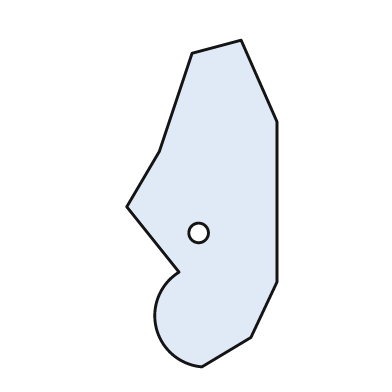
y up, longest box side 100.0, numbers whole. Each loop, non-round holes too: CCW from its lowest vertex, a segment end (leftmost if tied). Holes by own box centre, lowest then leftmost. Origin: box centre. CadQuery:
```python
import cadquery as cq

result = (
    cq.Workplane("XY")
    .moveTo(0.0, -50.0)
    .lineTo(15.0, -41.0)
    .lineTo(23.0, -24.0)
    .lineTo(23.0, 25.0)
    .lineTo(12.0, 50.0)
    .lineTo(-3.0, 46.0)
    .lineTo(-13.0, 16.0)
    .lineTo(-23.0, -1.0)
    .lineTo(-7.0, -21.0)
    .threePointArc((-14.0, -38.0), (0.0, -50.0))
    .close()
    .moveTo(-1.0, -9.0)
    .circle(3.0)
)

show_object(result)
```